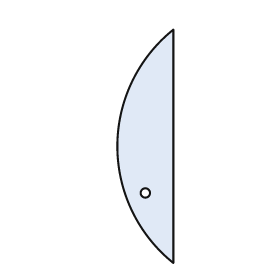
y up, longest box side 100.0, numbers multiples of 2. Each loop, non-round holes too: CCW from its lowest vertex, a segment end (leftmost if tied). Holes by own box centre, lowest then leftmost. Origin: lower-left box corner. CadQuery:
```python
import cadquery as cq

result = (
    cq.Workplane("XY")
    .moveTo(24.0, 0.0)
    .lineTo(24.0, 100.0)
    .threePointArc((0.0, 50.0), (24.0, 0.0))
    .close()
    .moveTo(12.0, 30.0)
    .circle(2.0)
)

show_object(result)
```